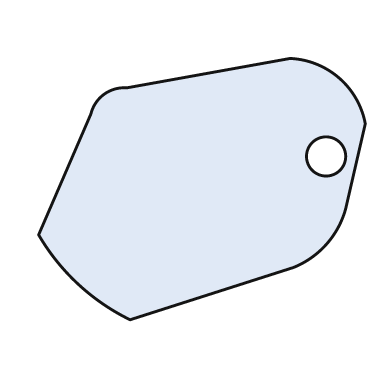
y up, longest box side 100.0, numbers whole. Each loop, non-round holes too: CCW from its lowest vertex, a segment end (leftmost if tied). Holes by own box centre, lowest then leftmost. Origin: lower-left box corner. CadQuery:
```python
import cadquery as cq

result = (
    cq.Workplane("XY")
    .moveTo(28.0, 0.0)
    .lineTo(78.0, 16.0)
    .threePointArc((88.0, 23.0), (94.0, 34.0))
    .lineTo(100.0, 60.0)
    .threePointArc((92.0, 74.0), (77.0, 80.0))
    .lineTo(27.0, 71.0)
    .threePointArc((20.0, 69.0), (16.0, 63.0))
    .lineTo(0.0, 26.0)
    .threePointArc((12.0, 11.0), (28.0, 0.0))
    .close()
    .moveTo(88.0, 50.0)
    .circle(6.0)
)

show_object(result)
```